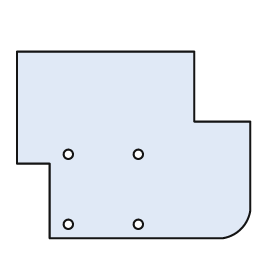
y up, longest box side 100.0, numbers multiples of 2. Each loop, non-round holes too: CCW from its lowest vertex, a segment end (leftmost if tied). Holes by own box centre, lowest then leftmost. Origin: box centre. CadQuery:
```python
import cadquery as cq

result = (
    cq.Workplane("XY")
    .moveTo(-36.0, -40.0)
    .lineTo(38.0, -40.0)
    .threePointArc((46.0, -36.0), (50.0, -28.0))
    .lineTo(50.0, 10.0)
    .lineTo(26.0, 10.0)
    .lineTo(26.0, 40.0)
    .lineTo(-50.0, 40.0)
    .lineTo(-50.0, -8.0)
    .lineTo(-36.0, -8.0)
    .close()
    .moveTo(-28.0, -34.0)
    .circle(2.0)
    .moveTo(2.0, -34.0)
    .circle(2.0)
    .moveTo(-28.0, -4.0)
    .circle(2.0)
    .moveTo(2.0, -4.0)
    .circle(2.0)
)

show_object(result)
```